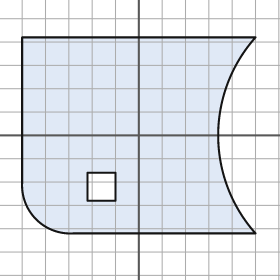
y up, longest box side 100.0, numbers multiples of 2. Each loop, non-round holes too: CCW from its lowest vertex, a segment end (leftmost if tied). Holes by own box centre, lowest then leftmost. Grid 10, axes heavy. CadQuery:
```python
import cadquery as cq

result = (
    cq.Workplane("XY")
    .moveTo(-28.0, -42.0)
    .lineTo(50.0, -42.0)
    .threePointArc((34.0, 0.0), (50.0, 42.0))
    .lineTo(-50.0, 42.0)
    .lineTo(-50.0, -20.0)
    .threePointArc((-44.0, -36.0), (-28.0, -42.0))
    .close()
    .moveTo(-22.0, -28.0)
    .lineTo(-10.0, -28.0)
    .lineTo(-10.0, -16.0)
    .lineTo(-22.0, -16.0)
    .close()
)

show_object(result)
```